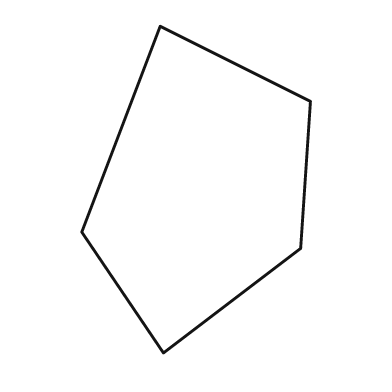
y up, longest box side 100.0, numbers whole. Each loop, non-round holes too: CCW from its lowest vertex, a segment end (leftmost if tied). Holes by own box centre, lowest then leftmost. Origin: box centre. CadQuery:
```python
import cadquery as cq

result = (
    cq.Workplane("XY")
    .moveTo(-10.0, -50.0)
    .lineTo(32.0, -18.0)
    .lineTo(35.0, 27.0)
    .lineTo(-11.0, 50.0)
    .lineTo(-35.0, -13.0)
    .close()
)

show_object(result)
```